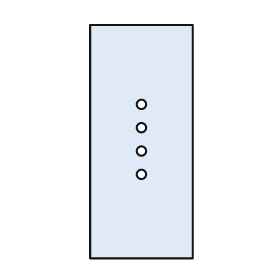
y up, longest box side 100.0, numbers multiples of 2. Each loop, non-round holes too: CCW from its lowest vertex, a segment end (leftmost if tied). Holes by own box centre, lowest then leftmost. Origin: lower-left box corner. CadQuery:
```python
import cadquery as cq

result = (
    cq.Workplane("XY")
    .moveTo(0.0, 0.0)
    .lineTo(44.0, 0.0)
    .lineTo(44.0, 100.0)
    .lineTo(0.0, 100.0)
    .close()
    .moveTo(22.0, 36.0)
    .circle(2.0)
    .moveTo(22.0, 46.0)
    .circle(2.0)
    .moveTo(22.0, 56.0)
    .circle(2.0)
    .moveTo(22.0, 66.0)
    .circle(2.0)
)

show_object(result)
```